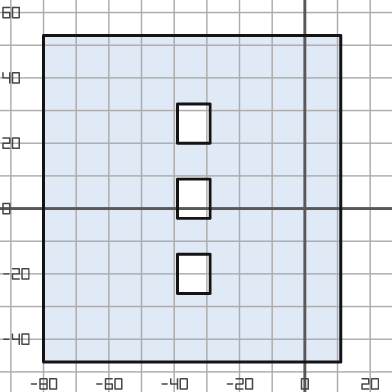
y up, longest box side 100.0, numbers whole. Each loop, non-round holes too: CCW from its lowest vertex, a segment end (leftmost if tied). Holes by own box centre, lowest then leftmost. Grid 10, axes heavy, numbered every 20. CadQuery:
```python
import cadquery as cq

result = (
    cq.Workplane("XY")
    .moveTo(-80.0, -47.0)
    .lineTo(11.0, -47.0)
    .lineTo(11.0, 53.0)
    .lineTo(-80.0, 53.0)
    .close()
    .moveTo(-39.0, -26.0)
    .lineTo(-29.0, -26.0)
    .lineTo(-29.0, -14.0)
    .lineTo(-39.0, -14.0)
    .close()
    .moveTo(-39.0, -3.0)
    .lineTo(-29.0, -3.0)
    .lineTo(-29.0, 9.0)
    .lineTo(-39.0, 9.0)
    .close()
    .moveTo(-39.0, 20.0)
    .lineTo(-29.0, 20.0)
    .lineTo(-29.0, 32.0)
    .lineTo(-39.0, 32.0)
    .close()
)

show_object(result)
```